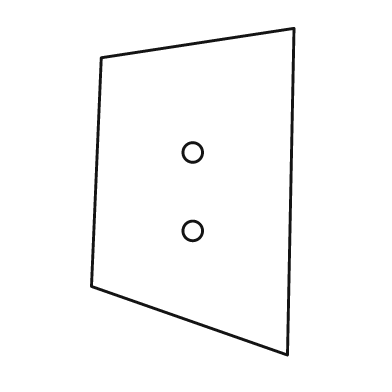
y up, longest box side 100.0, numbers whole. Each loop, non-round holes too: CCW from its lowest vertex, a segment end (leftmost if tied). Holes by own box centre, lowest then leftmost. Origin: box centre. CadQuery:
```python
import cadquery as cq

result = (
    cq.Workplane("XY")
    .moveTo(29.0, -50.0)
    .lineTo(31.0, 50.0)
    .lineTo(-28.0, 41.0)
    .lineTo(-31.0, -29.0)
    .close()
    .moveTo(0.0, -12.0)
    .circle(3.0)
    .moveTo(0.0, 12.0)
    .circle(3.0)
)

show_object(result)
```